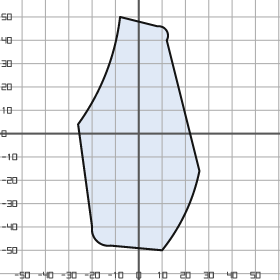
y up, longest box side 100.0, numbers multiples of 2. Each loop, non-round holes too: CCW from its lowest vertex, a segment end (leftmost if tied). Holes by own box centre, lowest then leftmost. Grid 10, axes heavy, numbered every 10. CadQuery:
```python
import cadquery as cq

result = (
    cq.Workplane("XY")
    .moveTo(10.0, -50.0)
    .threePointArc((20.0, -34.0), (26.0, -16.0))
    .lineTo(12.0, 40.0)
    .threePointArc((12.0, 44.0), (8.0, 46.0))
    .lineTo(-8.0, 50.0)
    .threePointArc((-14.0, 26.0), (-26.0, 4.0))
    .lineTo(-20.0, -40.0)
    .threePointArc((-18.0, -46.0), (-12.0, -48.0))
    .close()
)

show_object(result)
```